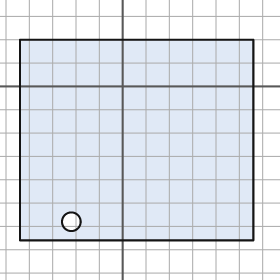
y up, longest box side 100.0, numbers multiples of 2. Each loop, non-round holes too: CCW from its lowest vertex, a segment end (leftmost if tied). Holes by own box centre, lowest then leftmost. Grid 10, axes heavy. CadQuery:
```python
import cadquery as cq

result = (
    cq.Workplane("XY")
    .moveTo(-44.0, -66.0)
    .lineTo(56.0, -66.0)
    .lineTo(56.0, 20.0)
    .lineTo(-44.0, 20.0)
    .close()
    .moveTo(-22.0, -58.0)
    .circle(4.0)
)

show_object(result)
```